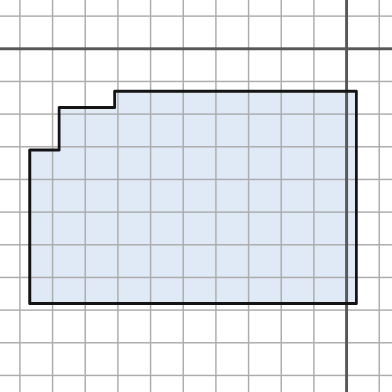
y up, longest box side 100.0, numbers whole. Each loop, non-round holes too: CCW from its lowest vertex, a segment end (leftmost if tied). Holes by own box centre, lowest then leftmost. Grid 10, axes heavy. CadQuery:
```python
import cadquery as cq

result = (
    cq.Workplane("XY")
    .moveTo(-97.0, -78.0)
    .lineTo(3.0, -78.0)
    .lineTo(3.0, -13.0)
    .lineTo(-71.0, -13.0)
    .lineTo(-71.0, -18.0)
    .lineTo(-88.0, -18.0)
    .lineTo(-88.0, -31.0)
    .lineTo(-97.0, -31.0)
    .close()
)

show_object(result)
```